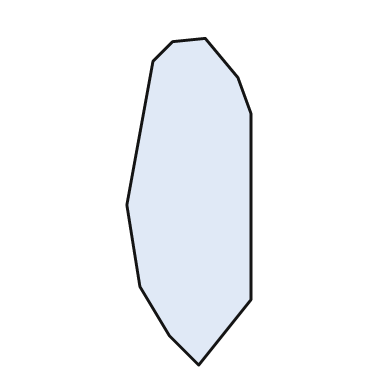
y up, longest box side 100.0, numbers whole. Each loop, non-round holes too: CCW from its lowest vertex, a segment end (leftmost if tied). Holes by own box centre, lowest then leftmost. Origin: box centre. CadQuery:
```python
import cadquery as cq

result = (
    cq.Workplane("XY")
    .moveTo(3.0, -50.0)
    .lineTo(19.0, -30.0)
    .lineTo(19.0, 27.0)
    .lineTo(15.0, 38.0)
    .lineTo(5.0, 50.0)
    .lineTo(-5.0, 49.0)
    .lineTo(-11.0, 43.0)
    .lineTo(-19.0, -1.0)
    .lineTo(-15.0, -26.0)
    .lineTo(-6.0, -41.0)
    .close()
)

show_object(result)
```